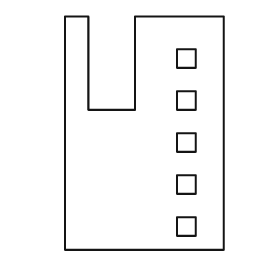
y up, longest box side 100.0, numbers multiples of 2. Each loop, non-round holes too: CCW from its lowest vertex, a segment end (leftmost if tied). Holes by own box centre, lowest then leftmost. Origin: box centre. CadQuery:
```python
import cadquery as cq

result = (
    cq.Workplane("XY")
    .moveTo(-34.0, -50.0)
    .lineTo(34.0, -50.0)
    .lineTo(34.0, 50.0)
    .lineTo(-4.0, 50.0)
    .lineTo(-4.0, 10.0)
    .lineTo(-24.0, 10.0)
    .lineTo(-24.0, 50.0)
    .lineTo(-34.0, 50.0)
    .close()
    .moveTo(14.0, -44.0)
    .lineTo(22.0, -44.0)
    .lineTo(22.0, -36.0)
    .lineTo(14.0, -36.0)
    .close()
    .moveTo(14.0, -26.0)
    .lineTo(22.0, -26.0)
    .lineTo(22.0, -18.0)
    .lineTo(14.0, -18.0)
    .close()
    .moveTo(14.0, -8.0)
    .lineTo(22.0, -8.0)
    .lineTo(22.0, 0.0)
    .lineTo(14.0, 0.0)
    .close()
    .moveTo(14.0, 10.0)
    .lineTo(22.0, 10.0)
    .lineTo(22.0, 18.0)
    .lineTo(14.0, 18.0)
    .close()
    .moveTo(14.0, 28.0)
    .lineTo(22.0, 28.0)
    .lineTo(22.0, 36.0)
    .lineTo(14.0, 36.0)
    .close()
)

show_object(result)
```